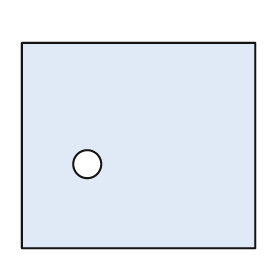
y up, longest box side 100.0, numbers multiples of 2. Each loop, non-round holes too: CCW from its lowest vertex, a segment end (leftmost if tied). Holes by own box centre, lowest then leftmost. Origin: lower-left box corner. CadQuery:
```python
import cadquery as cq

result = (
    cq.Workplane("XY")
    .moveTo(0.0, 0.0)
    .lineTo(100.0, 0.0)
    .lineTo(100.0, 88.0)
    .lineTo(0.0, 88.0)
    .close()
    .moveTo(28.0, 36.0)
    .circle(6.0)
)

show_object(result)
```